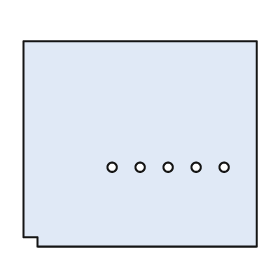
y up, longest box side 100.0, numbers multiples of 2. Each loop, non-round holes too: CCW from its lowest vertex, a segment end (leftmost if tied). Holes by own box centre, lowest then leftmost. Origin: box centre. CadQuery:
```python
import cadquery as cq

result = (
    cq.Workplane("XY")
    .moveTo(-44.0, -44.0)
    .lineTo(50.0, -44.0)
    .lineTo(50.0, 44.0)
    .lineTo(-50.0, 44.0)
    .lineTo(-50.0, -40.0)
    .lineTo(-44.0, -40.0)
    .close()
    .moveTo(-12.0, -10.0)
    .circle(2.0)
    .moveTo(0.0, -10.0)
    .circle(2.0)
    .moveTo(12.0, -10.0)
    .circle(2.0)
    .moveTo(24.0, -10.0)
    .circle(2.0)
    .moveTo(36.0, -10.0)
    .circle(2.0)
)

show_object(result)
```